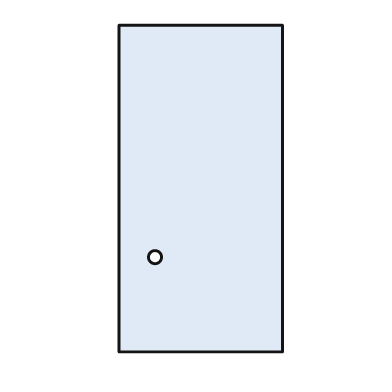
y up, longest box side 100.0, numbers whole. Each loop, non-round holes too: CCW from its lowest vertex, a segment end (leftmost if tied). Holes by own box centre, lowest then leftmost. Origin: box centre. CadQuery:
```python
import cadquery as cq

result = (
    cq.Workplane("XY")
    .moveTo(-25.0, -50.0)
    .lineTo(25.0, -50.0)
    .lineTo(25.0, 50.0)
    .lineTo(-25.0, 50.0)
    .close()
    .moveTo(-14.0, -21.0)
    .circle(2.0)
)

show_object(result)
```